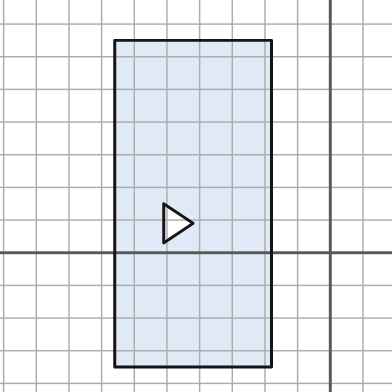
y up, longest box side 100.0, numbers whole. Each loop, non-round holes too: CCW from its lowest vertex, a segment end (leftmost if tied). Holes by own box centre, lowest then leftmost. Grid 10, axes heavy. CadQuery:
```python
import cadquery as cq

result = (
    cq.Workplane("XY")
    .moveTo(-66.0, -35.0)
    .lineTo(-18.0, -35.0)
    .lineTo(-18.0, 65.0)
    .lineTo(-66.0, 65.0)
    .close()
    .moveTo(-51.0, 3.0)
    .lineTo(-42.0, 9.0)
    .lineTo(-51.0, 15.0)
    .close()
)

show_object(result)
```